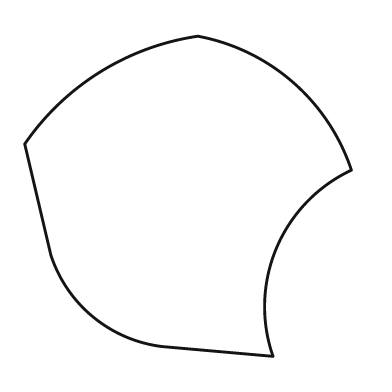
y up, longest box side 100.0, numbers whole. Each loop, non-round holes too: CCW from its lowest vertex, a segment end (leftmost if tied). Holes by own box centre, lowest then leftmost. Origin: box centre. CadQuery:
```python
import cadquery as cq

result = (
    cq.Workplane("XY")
    .moveTo(26.0, -49.0)
    .threePointArc((27.0, -16.0), (50.0, 8.0))
    .threePointArc((32.0, 35.0), (3.0, 49.0))
    .threePointArc((-27.0, 38.0), (-50.0, 16.0))
    .lineTo(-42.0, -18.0)
    .threePointArc((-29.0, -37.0), (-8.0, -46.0))
    .close()
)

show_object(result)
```